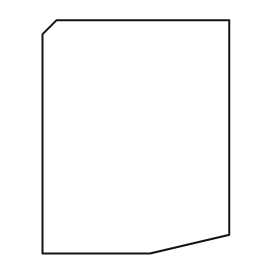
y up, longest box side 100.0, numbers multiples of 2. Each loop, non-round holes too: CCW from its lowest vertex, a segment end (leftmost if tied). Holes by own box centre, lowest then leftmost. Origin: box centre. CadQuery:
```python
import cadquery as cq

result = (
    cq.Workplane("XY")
    .moveTo(-40.0, -50.0)
    .lineTo(6.0, -50.0)
    .lineTo(40.0, -42.0)
    .lineTo(40.0, 50.0)
    .lineTo(-34.0, 50.0)
    .lineTo(-40.0, 44.0)
    .close()
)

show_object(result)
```